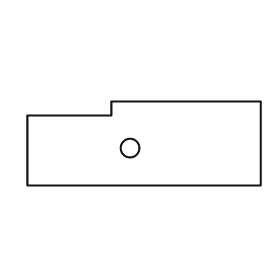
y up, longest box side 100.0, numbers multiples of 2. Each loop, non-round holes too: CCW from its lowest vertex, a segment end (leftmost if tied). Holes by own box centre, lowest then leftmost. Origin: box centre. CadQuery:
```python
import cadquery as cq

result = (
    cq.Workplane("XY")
    .moveTo(-50.0, -18.0)
    .lineTo(50.0, -18.0)
    .lineTo(50.0, 18.0)
    .lineTo(-14.0, 18.0)
    .lineTo(-14.0, 12.0)
    .lineTo(-50.0, 12.0)
    .close()
    .moveTo(-6.0, -2.0)
    .circle(4.0)
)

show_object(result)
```